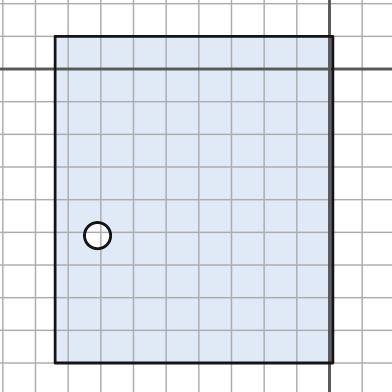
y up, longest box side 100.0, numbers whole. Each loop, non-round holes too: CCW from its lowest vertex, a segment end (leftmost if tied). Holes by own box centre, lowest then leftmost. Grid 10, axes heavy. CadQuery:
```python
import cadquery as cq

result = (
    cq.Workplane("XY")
    .moveTo(-84.0, -90.0)
    .lineTo(1.0, -90.0)
    .lineTo(1.0, 10.0)
    .lineTo(-84.0, 10.0)
    .close()
    .moveTo(-71.0, -51.0)
    .circle(4.0)
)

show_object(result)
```